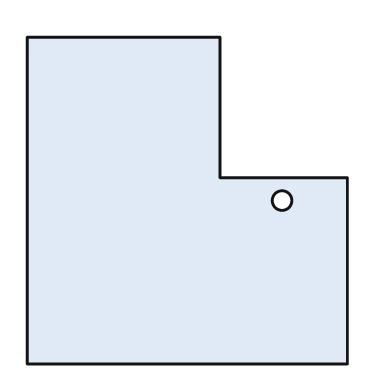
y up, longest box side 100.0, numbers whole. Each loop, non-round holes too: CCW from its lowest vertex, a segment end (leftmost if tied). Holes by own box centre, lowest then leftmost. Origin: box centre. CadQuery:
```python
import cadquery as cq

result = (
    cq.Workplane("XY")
    .moveTo(-49.0, -50.0)
    .lineTo(49.0, -50.0)
    .lineTo(49.0, 7.0)
    .lineTo(10.0, 7.0)
    .lineTo(10.0, 50.0)
    .lineTo(-49.0, 50.0)
    .close()
    .moveTo(29.0, 0.0)
    .circle(3.0)
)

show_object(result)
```